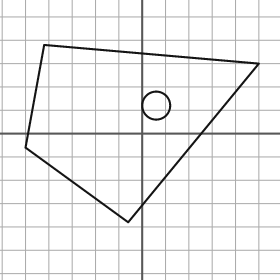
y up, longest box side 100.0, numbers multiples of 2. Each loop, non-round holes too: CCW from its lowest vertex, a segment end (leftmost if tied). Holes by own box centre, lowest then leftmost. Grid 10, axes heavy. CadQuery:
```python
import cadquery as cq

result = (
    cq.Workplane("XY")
    .moveTo(-6.0, -38.0)
    .lineTo(50.0, 30.0)
    .lineTo(-42.0, 38.0)
    .lineTo(-50.0, -6.0)
    .close()
    .moveTo(6.0, 12.0)
    .circle(6.0)
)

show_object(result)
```